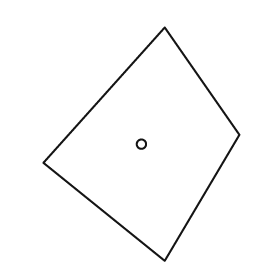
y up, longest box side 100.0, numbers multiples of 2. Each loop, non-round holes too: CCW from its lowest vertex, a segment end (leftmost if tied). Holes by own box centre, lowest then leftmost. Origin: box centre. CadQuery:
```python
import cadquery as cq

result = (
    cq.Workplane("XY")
    .moveTo(10.0, -50.0)
    .lineTo(42.0, 4.0)
    .lineTo(10.0, 50.0)
    .lineTo(-42.0, -8.0)
    .close()
    .moveTo(0.0, 0.0)
    .circle(2.0)
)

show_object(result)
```